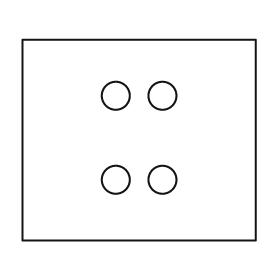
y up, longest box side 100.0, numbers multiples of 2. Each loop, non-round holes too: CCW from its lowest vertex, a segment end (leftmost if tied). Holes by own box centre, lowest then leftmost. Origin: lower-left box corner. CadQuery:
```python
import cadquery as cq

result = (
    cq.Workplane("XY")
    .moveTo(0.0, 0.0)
    .lineTo(100.0, 0.0)
    .lineTo(100.0, 86.0)
    .lineTo(0.0, 86.0)
    .close()
    .moveTo(40.0, 26.0)
    .circle(6.0)
    .moveTo(60.0, 26.0)
    .circle(6.0)
    .moveTo(40.0, 62.0)
    .circle(6.0)
    .moveTo(60.0, 62.0)
    .circle(6.0)
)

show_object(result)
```